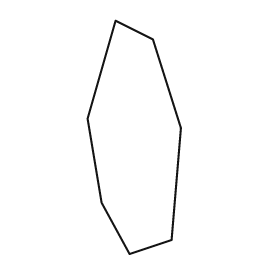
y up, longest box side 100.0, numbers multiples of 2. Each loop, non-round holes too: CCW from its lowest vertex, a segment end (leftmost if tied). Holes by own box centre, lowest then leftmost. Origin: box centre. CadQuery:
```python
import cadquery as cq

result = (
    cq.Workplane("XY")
    .moveTo(-2.0, -50.0)
    .lineTo(16.0, -44.0)
    .lineTo(20.0, 4.0)
    .lineTo(8.0, 42.0)
    .lineTo(-8.0, 50.0)
    .lineTo(-20.0, 8.0)
    .lineTo(-14.0, -28.0)
    .close()
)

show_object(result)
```